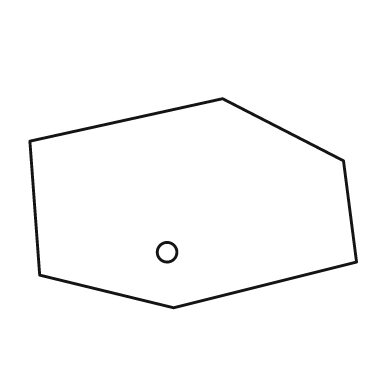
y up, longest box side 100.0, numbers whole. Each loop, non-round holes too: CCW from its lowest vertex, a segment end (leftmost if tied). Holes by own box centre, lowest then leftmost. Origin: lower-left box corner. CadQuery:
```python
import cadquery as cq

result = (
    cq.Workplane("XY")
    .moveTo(44.0, 0.0)
    .lineTo(100.0, 14.0)
    .lineTo(96.0, 45.0)
    .lineTo(59.0, 64.0)
    .lineTo(0.0, 51.0)
    .lineTo(3.0, 10.0)
    .close()
    .moveTo(42.0, 17.0)
    .circle(3.0)
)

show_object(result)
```